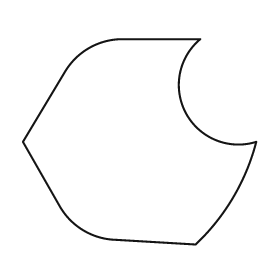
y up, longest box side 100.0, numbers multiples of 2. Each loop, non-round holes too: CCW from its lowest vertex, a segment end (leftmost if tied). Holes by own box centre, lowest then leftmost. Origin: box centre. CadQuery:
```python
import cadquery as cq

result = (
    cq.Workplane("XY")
    .moveTo(24.0, -44.0)
    .threePointArc((40.0, -24.0), (50.0, 0.0))
    .threePointArc((20.0, 12.0), (26.0, 44.0))
    .lineTo(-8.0, 44.0)
    .threePointArc((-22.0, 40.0), (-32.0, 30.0))
    .lineTo(-50.0, 0.0)
    .lineTo(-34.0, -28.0)
    .threePointArc((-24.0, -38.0), (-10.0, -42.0))
    .close()
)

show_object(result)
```